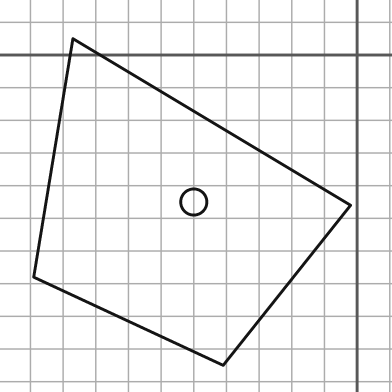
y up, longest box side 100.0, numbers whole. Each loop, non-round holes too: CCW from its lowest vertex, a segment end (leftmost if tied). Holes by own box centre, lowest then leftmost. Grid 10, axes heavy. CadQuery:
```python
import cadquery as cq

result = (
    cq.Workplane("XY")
    .moveTo(-41.0, -95.0)
    .lineTo(-2.0, -46.0)
    .lineTo(-87.0, 5.0)
    .lineTo(-99.0, -68.0)
    .close()
    .moveTo(-50.0, -45.0)
    .circle(4.0)
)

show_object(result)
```